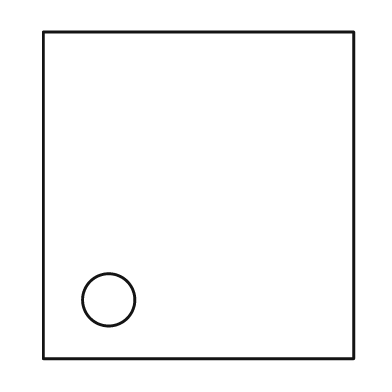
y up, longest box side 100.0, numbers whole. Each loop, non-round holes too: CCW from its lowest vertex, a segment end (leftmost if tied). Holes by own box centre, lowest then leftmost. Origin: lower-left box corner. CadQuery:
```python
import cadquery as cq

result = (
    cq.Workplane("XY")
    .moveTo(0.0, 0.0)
    .lineTo(95.0, 0.0)
    .lineTo(95.0, 100.0)
    .lineTo(0.0, 100.0)
    .close()
    .moveTo(20.0, 18.0)
    .circle(8.0)
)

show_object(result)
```